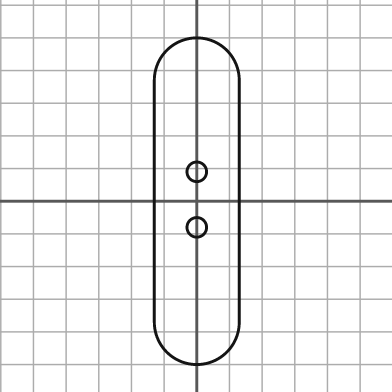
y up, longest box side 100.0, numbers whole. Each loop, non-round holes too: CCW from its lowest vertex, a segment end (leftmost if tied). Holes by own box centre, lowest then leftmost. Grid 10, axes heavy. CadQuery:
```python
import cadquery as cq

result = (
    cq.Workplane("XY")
    .moveTo(-13.0, -37.0)
    .threePointArc((0.0, -50.0), (13.0, -37.0))
    .lineTo(13.0, 37.0)
    .threePointArc((0.0, 50.0), (-13.0, 37.0))
    .close()
    .moveTo(0.0, -8.0)
    .circle(3.0)
    .moveTo(0.0, 9.0)
    .circle(3.0)
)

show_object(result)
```